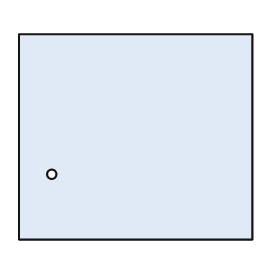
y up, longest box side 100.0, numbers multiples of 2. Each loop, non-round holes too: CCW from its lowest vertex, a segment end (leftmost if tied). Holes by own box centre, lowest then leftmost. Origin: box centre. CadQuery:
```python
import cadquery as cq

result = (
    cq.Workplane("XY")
    .moveTo(-50.0, -44.0)
    .lineTo(50.0, -44.0)
    .lineTo(50.0, 44.0)
    .lineTo(-50.0, 44.0)
    .close()
    .moveTo(-36.0, -16.0)
    .circle(2.0)
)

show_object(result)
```